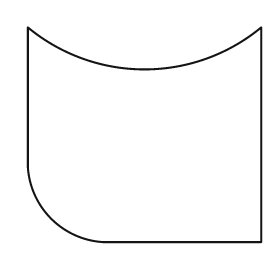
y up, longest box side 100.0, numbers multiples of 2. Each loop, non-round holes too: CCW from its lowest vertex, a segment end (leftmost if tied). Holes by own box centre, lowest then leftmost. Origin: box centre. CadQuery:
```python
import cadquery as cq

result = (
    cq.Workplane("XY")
    .moveTo(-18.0, -46.0)
    .lineTo(50.0, -46.0)
    .lineTo(50.0, 46.0)
    .threePointArc((0.0, 28.0), (-50.0, 46.0))
    .lineTo(-50.0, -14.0)
    .threePointArc((-40.0, -36.0), (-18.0, -46.0))
    .close()
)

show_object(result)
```